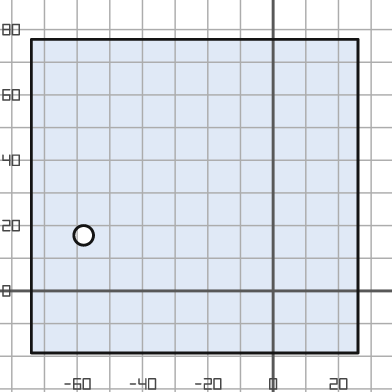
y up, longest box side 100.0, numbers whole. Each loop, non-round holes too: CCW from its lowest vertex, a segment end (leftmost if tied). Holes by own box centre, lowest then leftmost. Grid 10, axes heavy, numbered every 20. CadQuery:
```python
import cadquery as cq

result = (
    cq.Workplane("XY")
    .moveTo(-74.0, -19.0)
    .lineTo(26.0, -19.0)
    .lineTo(26.0, 77.0)
    .lineTo(-74.0, 77.0)
    .close()
    .moveTo(-58.0, 17.0)
    .circle(3.0)
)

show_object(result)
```